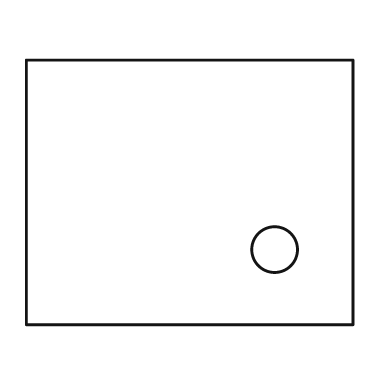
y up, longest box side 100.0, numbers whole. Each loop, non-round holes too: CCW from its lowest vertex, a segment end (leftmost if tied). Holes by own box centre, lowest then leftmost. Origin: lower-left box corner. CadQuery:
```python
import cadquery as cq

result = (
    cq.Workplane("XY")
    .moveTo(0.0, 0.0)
    .lineTo(100.0, 0.0)
    .lineTo(100.0, 81.0)
    .lineTo(0.0, 81.0)
    .close()
    .moveTo(76.0, 23.0)
    .circle(7.0)
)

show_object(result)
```